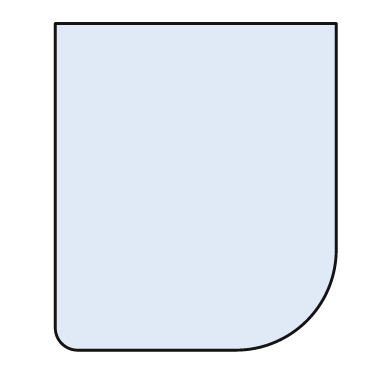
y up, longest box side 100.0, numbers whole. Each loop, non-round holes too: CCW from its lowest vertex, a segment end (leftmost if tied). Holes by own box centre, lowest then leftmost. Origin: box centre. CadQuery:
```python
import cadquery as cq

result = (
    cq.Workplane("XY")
    .moveTo(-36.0, -50.0)
    .lineTo(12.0, -50.0)
    .threePointArc((34.0, -41.0), (43.0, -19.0))
    .lineTo(43.0, 50.0)
    .lineTo(-43.0, 50.0)
    .lineTo(-43.0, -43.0)
    .threePointArc((-41.0, -48.0), (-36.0, -50.0))
    .close()
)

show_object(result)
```